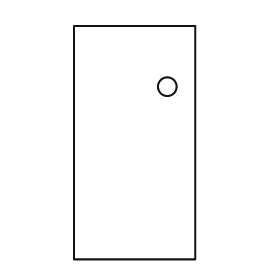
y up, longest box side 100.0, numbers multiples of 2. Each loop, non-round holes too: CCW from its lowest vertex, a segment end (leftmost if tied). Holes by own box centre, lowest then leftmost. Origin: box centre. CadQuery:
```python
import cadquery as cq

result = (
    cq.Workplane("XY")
    .moveTo(-26.0, -50.0)
    .lineTo(26.0, -50.0)
    .lineTo(26.0, 50.0)
    .lineTo(-26.0, 50.0)
    .close()
    .moveTo(14.0, 24.0)
    .circle(4.0)
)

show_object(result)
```